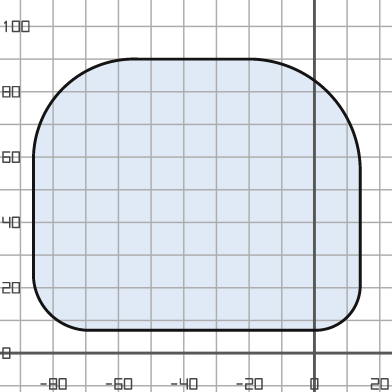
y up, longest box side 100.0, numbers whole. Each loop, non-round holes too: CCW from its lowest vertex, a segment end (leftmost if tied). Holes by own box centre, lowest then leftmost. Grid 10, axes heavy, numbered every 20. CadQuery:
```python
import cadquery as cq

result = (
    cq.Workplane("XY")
    .moveTo(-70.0, 7.0)
    .lineTo(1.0, 7.0)
    .threePointArc((10.0, 11.0), (14.0, 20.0))
    .lineTo(14.0, 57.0)
    .threePointArc((4.0, 80.0), (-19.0, 90.0))
    .lineTo(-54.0, 90.0)
    .threePointArc((-77.0, 81.0), (-86.0, 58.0))
    .lineTo(-86.0, 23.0)
    .threePointArc((-81.0, 12.0), (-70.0, 7.0))
    .close()
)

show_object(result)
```